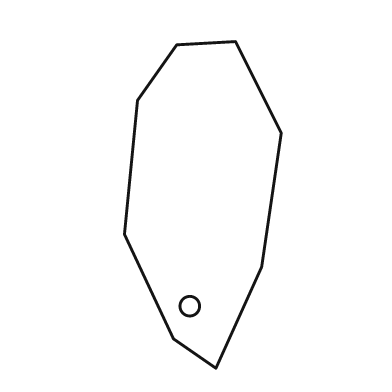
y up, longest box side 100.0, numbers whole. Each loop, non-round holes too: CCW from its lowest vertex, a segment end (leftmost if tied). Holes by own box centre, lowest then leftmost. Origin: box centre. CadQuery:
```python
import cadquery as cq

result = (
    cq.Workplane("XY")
    .moveTo(4.0, -50.0)
    .lineTo(18.0, -19.0)
    .lineTo(24.0, 22.0)
    .lineTo(10.0, 50.0)
    .lineTo(-8.0, 49.0)
    .lineTo(-20.0, 32.0)
    .lineTo(-24.0, -9.0)
    .lineTo(-9.0, -41.0)
    .close()
    .moveTo(-4.0, -31.0)
    .circle(3.0)
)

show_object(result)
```